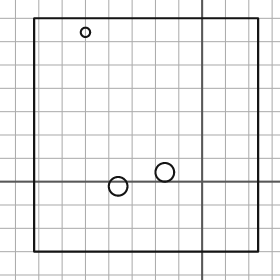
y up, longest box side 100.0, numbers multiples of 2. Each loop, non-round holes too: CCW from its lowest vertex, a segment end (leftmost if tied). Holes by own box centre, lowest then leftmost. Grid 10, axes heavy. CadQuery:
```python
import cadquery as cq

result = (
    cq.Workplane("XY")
    .moveTo(-72.0, -30.0)
    .lineTo(24.0, -30.0)
    .lineTo(24.0, 70.0)
    .lineTo(-72.0, 70.0)
    .close()
    .moveTo(-36.0, -2.0)
    .circle(4.0)
    .moveTo(-16.0, 4.0)
    .circle(4.0)
    .moveTo(-50.0, 64.0)
    .circle(2.0)
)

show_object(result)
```